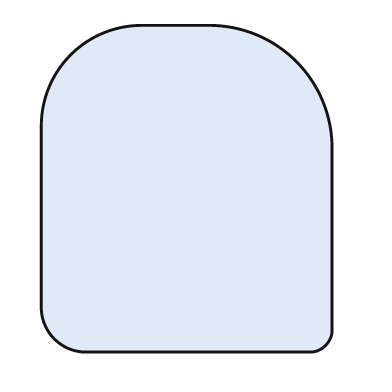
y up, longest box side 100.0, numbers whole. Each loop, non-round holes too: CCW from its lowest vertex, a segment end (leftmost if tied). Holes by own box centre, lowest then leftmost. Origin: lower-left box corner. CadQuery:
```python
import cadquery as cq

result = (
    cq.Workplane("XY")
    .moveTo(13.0, 0.0)
    .lineTo(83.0, 0.0)
    .threePointArc((87.0, 2.0), (89.0, 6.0))
    .lineTo(89.0, 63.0)
    .threePointArc((78.0, 89.0), (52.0, 100.0))
    .lineTo(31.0, 100.0)
    .threePointArc((9.0, 91.0), (0.0, 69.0))
    .lineTo(0.0, 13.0)
    .threePointArc((4.0, 4.0), (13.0, 0.0))
    .close()
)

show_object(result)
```